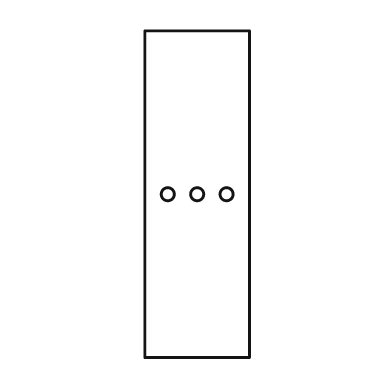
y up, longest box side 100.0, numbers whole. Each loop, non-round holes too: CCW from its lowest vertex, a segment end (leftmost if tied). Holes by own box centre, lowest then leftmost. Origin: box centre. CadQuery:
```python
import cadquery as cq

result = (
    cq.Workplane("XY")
    .moveTo(-16.0, -50.0)
    .lineTo(16.0, -50.0)
    .lineTo(16.0, 50.0)
    .lineTo(-16.0, 50.0)
    .close()
    .moveTo(-9.0, 0.0)
    .circle(2.0)
    .moveTo(0.0, 0.0)
    .circle(2.0)
    .moveTo(9.0, 0.0)
    .circle(2.0)
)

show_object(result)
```